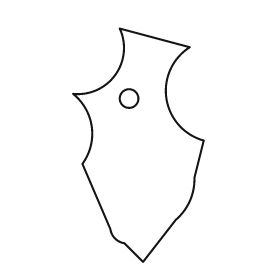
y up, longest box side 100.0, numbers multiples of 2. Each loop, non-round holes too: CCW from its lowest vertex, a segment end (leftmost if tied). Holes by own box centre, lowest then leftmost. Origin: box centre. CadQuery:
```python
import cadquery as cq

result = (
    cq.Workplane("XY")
    .moveTo(2.0, -50.0)
    .lineTo(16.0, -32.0)
    .threePointArc((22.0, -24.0), (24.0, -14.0))
    .lineTo(28.0, 2.0)
    .threePointArc((12.0, 20.0), (22.0, 42.0))
    .lineTo(-8.0, 50.0)
    .threePointArc((-10.0, 30.0), (-28.0, 22.0))
    .threePointArc((-20.0, 8.0), (-24.0, -8.0))
    .lineTo(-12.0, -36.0)
    .threePointArc((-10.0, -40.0), (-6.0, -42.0))
    .close()
    .moveTo(-4.0, 20.0)
    .circle(4.0)
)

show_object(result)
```